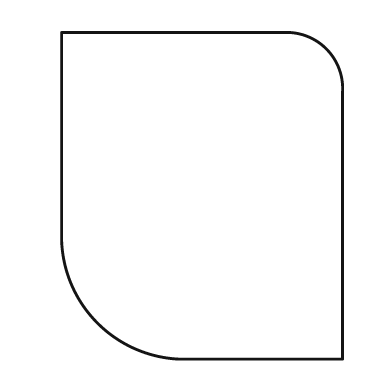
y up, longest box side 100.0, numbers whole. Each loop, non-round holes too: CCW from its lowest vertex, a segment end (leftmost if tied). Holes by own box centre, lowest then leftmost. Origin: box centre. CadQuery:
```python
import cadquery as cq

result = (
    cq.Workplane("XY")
    .moveTo(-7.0, -50.0)
    .lineTo(43.0, -50.0)
    .lineTo(43.0, 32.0)
    .threePointArc((38.0, 45.0), (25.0, 50.0))
    .lineTo(-43.0, 50.0)
    .lineTo(-43.0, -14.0)
    .threePointArc((-32.0, -39.0), (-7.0, -50.0))
    .close()
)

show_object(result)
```